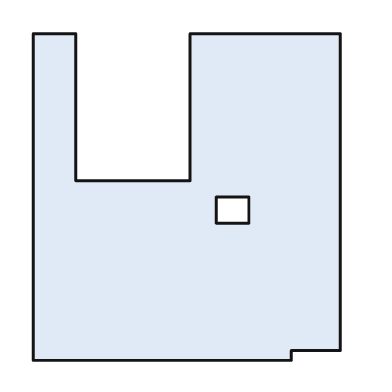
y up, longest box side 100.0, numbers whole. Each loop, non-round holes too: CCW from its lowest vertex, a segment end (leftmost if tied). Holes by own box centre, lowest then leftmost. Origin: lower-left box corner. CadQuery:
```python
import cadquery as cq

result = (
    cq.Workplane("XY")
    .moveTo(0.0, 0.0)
    .lineTo(79.0, 0.0)
    .lineTo(79.0, 3.0)
    .lineTo(94.0, 3.0)
    .lineTo(94.0, 100.0)
    .lineTo(48.0, 100.0)
    .lineTo(48.0, 55.0)
    .lineTo(13.0, 55.0)
    .lineTo(13.0, 100.0)
    .lineTo(0.0, 100.0)
    .close()
    .moveTo(56.0, 42.0)
    .lineTo(66.0, 42.0)
    .lineTo(66.0, 50.0)
    .lineTo(56.0, 50.0)
    .close()
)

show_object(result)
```